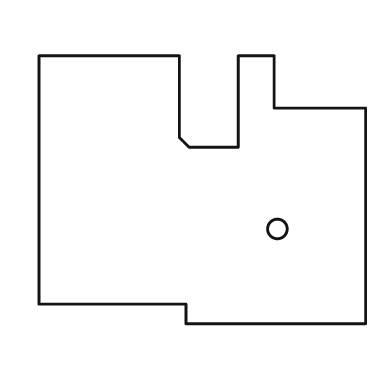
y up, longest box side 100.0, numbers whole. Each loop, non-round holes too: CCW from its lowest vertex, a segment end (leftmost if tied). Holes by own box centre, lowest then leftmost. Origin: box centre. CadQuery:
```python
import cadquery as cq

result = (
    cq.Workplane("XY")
    .moveTo(-5.0, -41.0)
    .lineTo(50.0, -41.0)
    .lineTo(50.0, 25.0)
    .lineTo(22.0, 25.0)
    .lineTo(22.0, 41.0)
    .lineTo(11.0, 41.0)
    .lineTo(11.0, 13.0)
    .lineTo(-4.0, 13.0)
    .lineTo(-7.0, 16.0)
    .lineTo(-7.0, 41.0)
    .lineTo(-50.0, 41.0)
    .lineTo(-50.0, -35.0)
    .lineTo(-5.0, -35.0)
    .close()
    .moveTo(23.0, -12.0)
    .circle(3.0)
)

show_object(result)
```